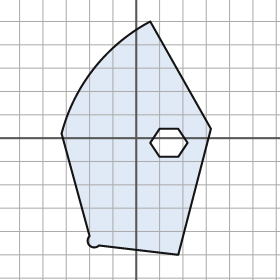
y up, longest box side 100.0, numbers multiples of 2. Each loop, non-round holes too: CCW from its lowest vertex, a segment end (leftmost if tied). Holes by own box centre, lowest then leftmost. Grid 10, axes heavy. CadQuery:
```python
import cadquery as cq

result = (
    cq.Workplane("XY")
    .moveTo(18.0, -50.0)
    .lineTo(32.0, 4.0)
    .lineTo(6.0, 50.0)
    .threePointArc((-18.0, 30.0), (-32.0, 2.0))
    .lineTo(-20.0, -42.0)
    .threePointArc((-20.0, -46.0), (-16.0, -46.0))
    .close()
    .moveTo(10.0, -8.0)
    .lineTo(18.0, -8.0)
    .lineTo(22.0, -2.0)
    .lineTo(18.0, 4.0)
    .lineTo(10.0, 4.0)
    .lineTo(6.0, -2.0)
    .close()
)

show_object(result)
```